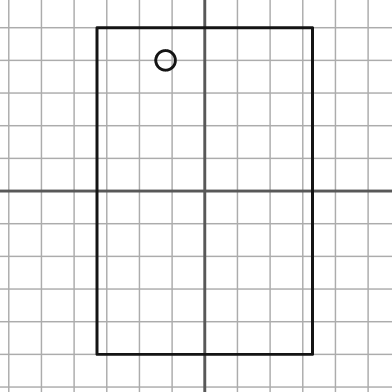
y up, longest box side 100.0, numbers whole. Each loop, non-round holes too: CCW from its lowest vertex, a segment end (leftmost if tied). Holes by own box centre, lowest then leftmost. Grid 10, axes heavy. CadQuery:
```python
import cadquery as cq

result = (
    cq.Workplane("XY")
    .moveTo(-33.0, -50.0)
    .lineTo(33.0, -50.0)
    .lineTo(33.0, 50.0)
    .lineTo(-33.0, 50.0)
    .close()
    .moveTo(-12.0, 40.0)
    .circle(3.0)
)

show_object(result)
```